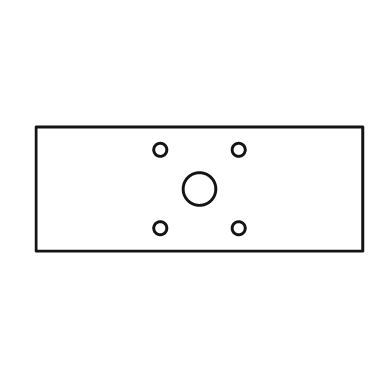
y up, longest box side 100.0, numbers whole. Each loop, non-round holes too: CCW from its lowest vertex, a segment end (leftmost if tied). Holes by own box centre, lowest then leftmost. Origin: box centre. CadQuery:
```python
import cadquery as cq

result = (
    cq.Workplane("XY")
    .moveTo(-50.0, -19.0)
    .lineTo(50.0, -19.0)
    .lineTo(50.0, 19.0)
    .lineTo(-50.0, 19.0)
    .close()
    .moveTo(-12.0, -12.0)
    .circle(2.0)
    .moveTo(12.0, -12.0)
    .circle(2.0)
    .moveTo(0.0, 0.0)
    .circle(5.0)
    .moveTo(-12.0, 12.0)
    .circle(2.0)
    .moveTo(12.0, 12.0)
    .circle(2.0)
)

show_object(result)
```